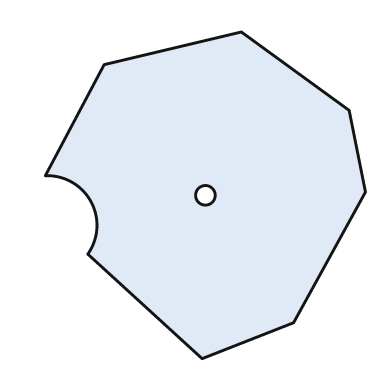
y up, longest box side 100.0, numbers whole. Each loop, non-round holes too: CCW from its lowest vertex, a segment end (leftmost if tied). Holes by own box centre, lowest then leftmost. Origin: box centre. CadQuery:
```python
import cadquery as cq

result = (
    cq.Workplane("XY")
    .moveTo(-1.0, -50.0)
    .lineTo(27.0, -39.0)
    .lineTo(49.0, 1.0)
    .lineTo(44.0, 26.0)
    .lineTo(11.0, 50.0)
    .lineTo(-31.0, 40.0)
    .lineTo(-49.0, 6.0)
    .threePointArc((-35.0, -2.0), (-36.0, -18.0))
    .close()
    .moveTo(0.0, 0.0)
    .circle(3.0)
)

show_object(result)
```